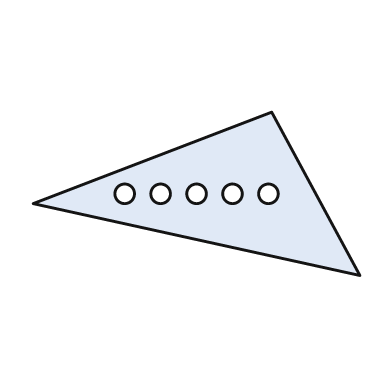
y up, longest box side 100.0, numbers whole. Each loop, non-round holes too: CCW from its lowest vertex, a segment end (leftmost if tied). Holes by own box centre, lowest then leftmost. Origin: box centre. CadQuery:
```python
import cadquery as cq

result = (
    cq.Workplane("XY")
    .moveTo(50.0, -25.0)
    .lineTo(23.0, 25.0)
    .lineTo(-50.0, -3.0)
    .close()
    .moveTo(-22.0, 0.0)
    .circle(3.0)
    .moveTo(-11.0, 0.0)
    .circle(3.0)
    .moveTo(0.0, 0.0)
    .circle(3.0)
    .moveTo(11.0, 0.0)
    .circle(3.0)
    .moveTo(22.0, 0.0)
    .circle(3.0)
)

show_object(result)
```